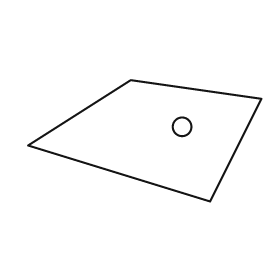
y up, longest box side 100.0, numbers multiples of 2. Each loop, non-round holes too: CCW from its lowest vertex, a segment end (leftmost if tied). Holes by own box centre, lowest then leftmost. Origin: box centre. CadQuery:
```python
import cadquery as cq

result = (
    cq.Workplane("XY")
    .moveTo(28.0, -26.0)
    .lineTo(50.0, 18.0)
    .lineTo(-6.0, 26.0)
    .lineTo(-50.0, -2.0)
    .close()
    .moveTo(16.0, 6.0)
    .circle(4.0)
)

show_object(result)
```